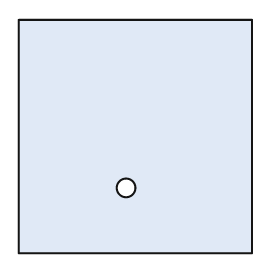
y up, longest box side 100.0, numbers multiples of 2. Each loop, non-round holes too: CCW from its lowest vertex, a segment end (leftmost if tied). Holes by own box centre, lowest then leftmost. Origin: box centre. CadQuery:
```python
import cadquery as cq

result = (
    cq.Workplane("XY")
    .moveTo(-50.0, -50.0)
    .lineTo(50.0, -50.0)
    .lineTo(50.0, 50.0)
    .lineTo(-50.0, 50.0)
    .close()
    .moveTo(-4.0, -22.0)
    .circle(4.0)
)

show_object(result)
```